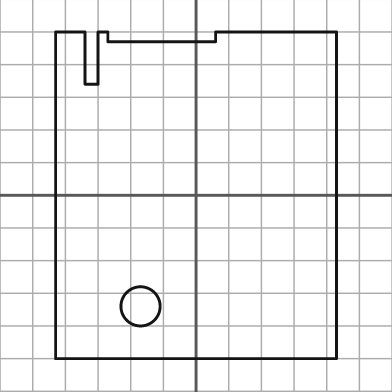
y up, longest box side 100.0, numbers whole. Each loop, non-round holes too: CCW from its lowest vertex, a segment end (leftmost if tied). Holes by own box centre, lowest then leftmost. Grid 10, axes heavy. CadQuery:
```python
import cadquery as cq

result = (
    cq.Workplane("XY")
    .moveTo(-43.0, -50.0)
    .lineTo(43.0, -50.0)
    .lineTo(43.0, 50.0)
    .lineTo(6.0, 50.0)
    .lineTo(6.0, 47.0)
    .lineTo(-27.0, 47.0)
    .lineTo(-27.0, 50.0)
    .lineTo(-30.0, 50.0)
    .lineTo(-30.0, 34.0)
    .lineTo(-34.0, 34.0)
    .lineTo(-34.0, 50.0)
    .lineTo(-43.0, 50.0)
    .close()
    .moveTo(-17.0, -34.0)
    .circle(6.0)
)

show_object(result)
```